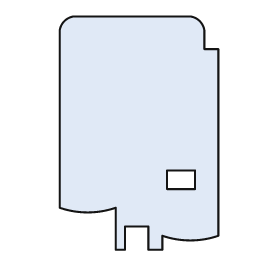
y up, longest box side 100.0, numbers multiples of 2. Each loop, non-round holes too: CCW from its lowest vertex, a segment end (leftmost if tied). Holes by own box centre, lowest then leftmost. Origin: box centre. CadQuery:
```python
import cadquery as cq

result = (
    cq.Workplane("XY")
    .moveTo(-10.0, -50.0)
    .lineTo(-6.0, -50.0)
    .lineTo(-6.0, -40.0)
    .lineTo(4.0, -40.0)
    .lineTo(4.0, -50.0)
    .lineTo(10.0, -50.0)
    .lineTo(10.0, -44.0)
    .threePointArc((22.0, -46.0), (34.0, -44.0))
    .lineTo(34.0, 36.0)
    .lineTo(28.0, 36.0)
    .lineTo(28.0, 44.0)
    .threePointArc((26.0, 48.0), (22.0, 50.0))
    .lineTo(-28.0, 50.0)
    .threePointArc((-32.0, 48.0), (-34.0, 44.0))
    .lineTo(-34.0, -32.0)
    .threePointArc((-22.0, -34.0), (-10.0, -32.0))
    .close()
    .moveTo(12.0, -24.0)
    .lineTo(24.0, -24.0)
    .lineTo(24.0, -16.0)
    .lineTo(12.0, -16.0)
    .close()
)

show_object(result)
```